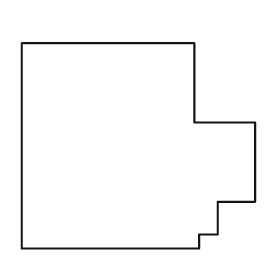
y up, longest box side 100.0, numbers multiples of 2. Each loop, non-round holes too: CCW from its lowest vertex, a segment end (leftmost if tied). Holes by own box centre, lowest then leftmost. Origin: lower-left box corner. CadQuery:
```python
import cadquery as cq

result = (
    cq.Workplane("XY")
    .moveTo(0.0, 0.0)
    .lineTo(76.0, 0.0)
    .lineTo(76.0, 6.0)
    .lineTo(84.0, 6.0)
    .lineTo(84.0, 20.0)
    .lineTo(100.0, 20.0)
    .lineTo(100.0, 54.0)
    .lineTo(74.0, 54.0)
    .lineTo(74.0, 88.0)
    .lineTo(0.0, 88.0)
    .close()
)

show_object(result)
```